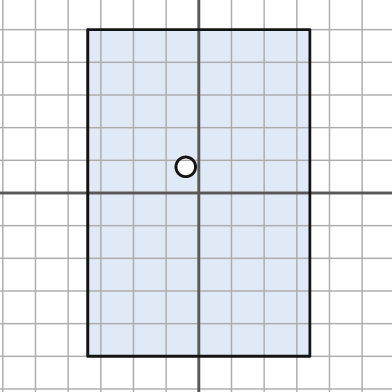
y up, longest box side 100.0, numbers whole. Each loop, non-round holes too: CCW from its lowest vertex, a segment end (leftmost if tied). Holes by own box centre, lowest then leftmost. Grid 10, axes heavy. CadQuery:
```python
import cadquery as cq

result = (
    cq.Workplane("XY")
    .moveTo(-34.0, -50.0)
    .lineTo(34.0, -50.0)
    .lineTo(34.0, 50.0)
    .lineTo(-34.0, 50.0)
    .close()
    .moveTo(-4.0, 8.0)
    .circle(3.0)
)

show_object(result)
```